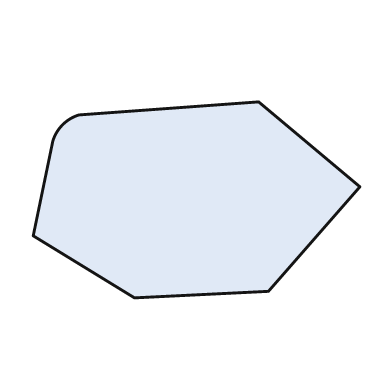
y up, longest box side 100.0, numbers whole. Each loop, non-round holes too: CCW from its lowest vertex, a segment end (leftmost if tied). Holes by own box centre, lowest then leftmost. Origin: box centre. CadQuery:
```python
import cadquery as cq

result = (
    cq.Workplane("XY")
    .moveTo(-19.0, -30.0)
    .lineTo(22.0, -28.0)
    .lineTo(50.0, 4.0)
    .lineTo(19.0, 30.0)
    .lineTo(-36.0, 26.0)
    .threePointArc((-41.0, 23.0), (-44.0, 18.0))
    .lineTo(-50.0, -11.0)
    .close()
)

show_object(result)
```